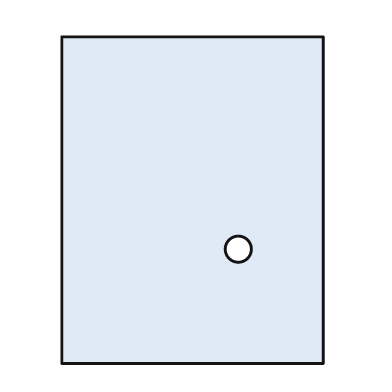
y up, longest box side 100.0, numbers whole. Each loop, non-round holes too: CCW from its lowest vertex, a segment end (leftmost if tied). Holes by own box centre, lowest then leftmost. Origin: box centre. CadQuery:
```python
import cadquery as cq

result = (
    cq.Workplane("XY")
    .moveTo(-40.0, -50.0)
    .lineTo(40.0, -50.0)
    .lineTo(40.0, 50.0)
    .lineTo(-40.0, 50.0)
    .close()
    .moveTo(14.0, -15.0)
    .circle(4.0)
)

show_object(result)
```